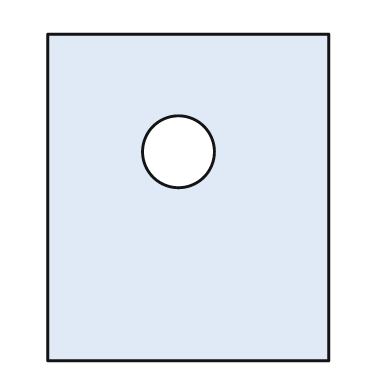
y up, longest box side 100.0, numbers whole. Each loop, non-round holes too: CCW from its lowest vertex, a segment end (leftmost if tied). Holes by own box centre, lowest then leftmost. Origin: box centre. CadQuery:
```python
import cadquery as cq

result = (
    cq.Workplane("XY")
    .moveTo(-43.0, -50.0)
    .lineTo(43.0, -50.0)
    .lineTo(43.0, 50.0)
    .lineTo(-43.0, 50.0)
    .close()
    .moveTo(-3.0, 14.0)
    .circle(11.0)
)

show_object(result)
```